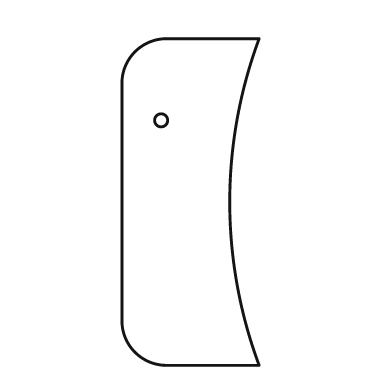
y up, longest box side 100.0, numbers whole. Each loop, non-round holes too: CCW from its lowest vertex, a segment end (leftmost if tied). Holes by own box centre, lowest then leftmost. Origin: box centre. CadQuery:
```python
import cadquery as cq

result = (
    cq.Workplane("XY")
    .moveTo(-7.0, -50.0)
    .lineTo(21.0, -50.0)
    .threePointArc((12.0, 0.0), (21.0, 50.0))
    .lineTo(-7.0, 50.0)
    .threePointArc((-17.0, 46.0), (-21.0, 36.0))
    .lineTo(-21.0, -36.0)
    .threePointArc((-17.0, -46.0), (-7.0, -50.0))
    .close()
    .moveTo(-9.0, 25.0)
    .circle(2.0)
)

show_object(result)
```